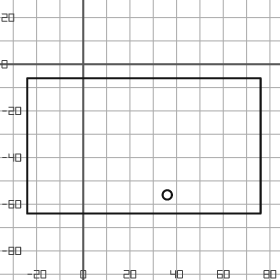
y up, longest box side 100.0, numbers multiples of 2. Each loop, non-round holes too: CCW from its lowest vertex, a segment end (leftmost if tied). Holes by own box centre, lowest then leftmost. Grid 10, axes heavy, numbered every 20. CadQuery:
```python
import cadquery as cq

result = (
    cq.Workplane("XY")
    .moveTo(-24.0, -64.0)
    .lineTo(76.0, -64.0)
    .lineTo(76.0, -6.0)
    .lineTo(-24.0, -6.0)
    .close()
    .moveTo(36.0, -56.0)
    .circle(2.0)
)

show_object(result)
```